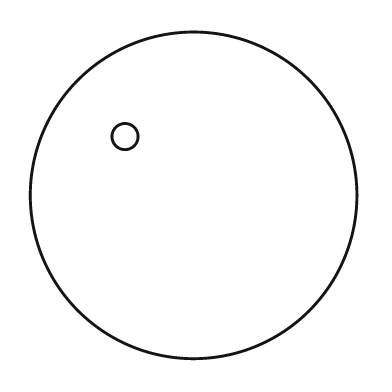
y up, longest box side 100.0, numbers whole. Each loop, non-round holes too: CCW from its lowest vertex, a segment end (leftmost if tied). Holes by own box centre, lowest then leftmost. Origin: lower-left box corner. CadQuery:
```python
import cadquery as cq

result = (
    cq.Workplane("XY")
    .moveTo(50.0, 50.0)
    .circle(50.0)
    .moveTo(29.0, 68.0)
    .circle(4.0)
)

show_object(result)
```